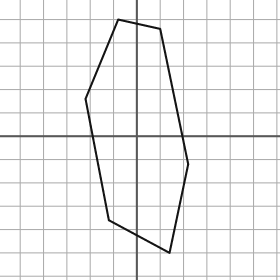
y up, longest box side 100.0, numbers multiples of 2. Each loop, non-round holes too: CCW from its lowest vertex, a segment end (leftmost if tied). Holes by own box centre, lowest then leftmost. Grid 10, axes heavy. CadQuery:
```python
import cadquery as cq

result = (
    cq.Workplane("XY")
    .moveTo(14.0, -50.0)
    .lineTo(22.0, -12.0)
    .lineTo(10.0, 46.0)
    .lineTo(-8.0, 50.0)
    .lineTo(-22.0, 16.0)
    .lineTo(-12.0, -36.0)
    .close()
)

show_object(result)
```